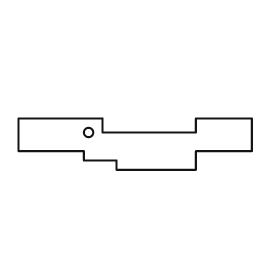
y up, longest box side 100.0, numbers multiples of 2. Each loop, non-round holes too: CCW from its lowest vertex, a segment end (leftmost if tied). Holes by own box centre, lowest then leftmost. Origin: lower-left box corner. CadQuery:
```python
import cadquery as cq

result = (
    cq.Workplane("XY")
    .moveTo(42.0, 0.0)
    .lineTo(76.0, 0.0)
    .lineTo(76.0, 8.0)
    .lineTo(100.0, 8.0)
    .lineTo(100.0, 22.0)
    .lineTo(76.0, 22.0)
    .lineTo(76.0, 16.0)
    .lineTo(36.0, 16.0)
    .lineTo(36.0, 22.0)
    .lineTo(0.0, 22.0)
    .lineTo(0.0, 8.0)
    .lineTo(28.0, 8.0)
    .lineTo(28.0, 4.0)
    .lineTo(42.0, 4.0)
    .close()
    .moveTo(30.0, 16.0)
    .circle(2.0)
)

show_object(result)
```